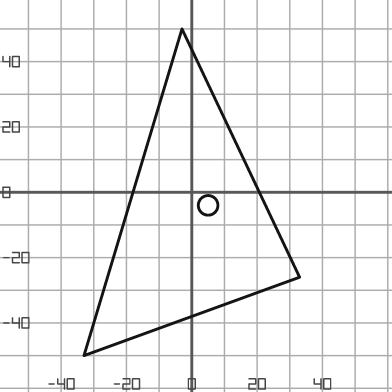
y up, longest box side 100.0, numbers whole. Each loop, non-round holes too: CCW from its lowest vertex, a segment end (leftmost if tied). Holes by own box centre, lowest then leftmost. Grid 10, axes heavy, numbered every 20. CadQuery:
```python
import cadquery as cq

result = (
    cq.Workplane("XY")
    .moveTo(-33.0, -50.0)
    .lineTo(33.0, -26.0)
    .lineTo(-3.0, 50.0)
    .close()
    .moveTo(5.0, -4.0)
    .circle(3.0)
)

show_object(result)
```